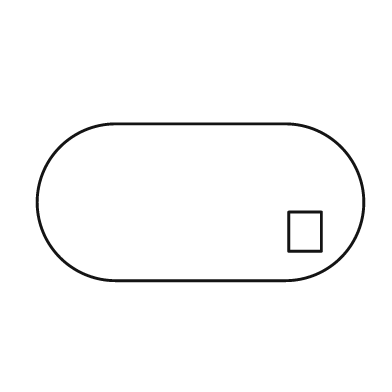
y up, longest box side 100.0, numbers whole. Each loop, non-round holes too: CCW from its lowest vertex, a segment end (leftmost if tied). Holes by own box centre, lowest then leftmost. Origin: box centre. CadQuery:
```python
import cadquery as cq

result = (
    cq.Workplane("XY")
    .moveTo(-26.0, -24.0)
    .lineTo(26.0, -24.0)
    .threePointArc((50.0, 0.0), (26.0, 24.0))
    .lineTo(-26.0, 24.0)
    .threePointArc((-50.0, 0.0), (-26.0, -24.0))
    .close()
    .moveTo(27.0, -15.0)
    .lineTo(37.0, -15.0)
    .lineTo(37.0, -3.0)
    .lineTo(27.0, -3.0)
    .close()
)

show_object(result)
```